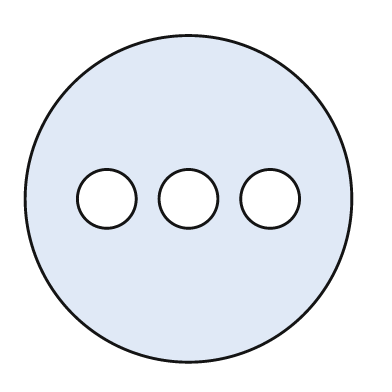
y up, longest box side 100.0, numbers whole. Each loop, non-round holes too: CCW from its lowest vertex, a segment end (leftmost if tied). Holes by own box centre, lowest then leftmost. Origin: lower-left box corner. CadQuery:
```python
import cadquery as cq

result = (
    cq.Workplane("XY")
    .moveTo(50.0, 50.0)
    .circle(50.0)
    .moveTo(25.0, 50.0)
    .circle(9.0)
    .moveTo(50.0, 50.0)
    .circle(9.0)
    .moveTo(75.0, 50.0)
    .circle(9.0)
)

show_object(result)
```